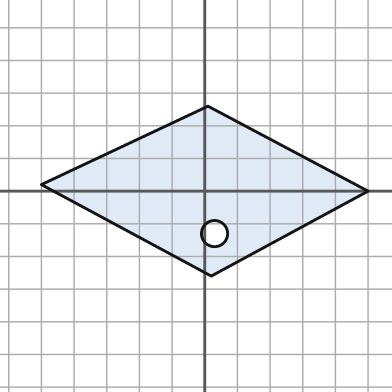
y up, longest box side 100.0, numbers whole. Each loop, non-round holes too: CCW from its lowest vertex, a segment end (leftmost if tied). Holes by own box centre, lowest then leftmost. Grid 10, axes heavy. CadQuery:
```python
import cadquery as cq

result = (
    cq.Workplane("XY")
    .moveTo(2.0, -26.0)
    .lineTo(50.0, 0.0)
    .lineTo(1.0, 26.0)
    .lineTo(-50.0, 2.0)
    .close()
    .moveTo(3.0, -13.0)
    .circle(4.0)
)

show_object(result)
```